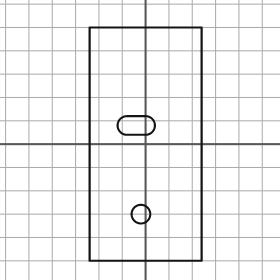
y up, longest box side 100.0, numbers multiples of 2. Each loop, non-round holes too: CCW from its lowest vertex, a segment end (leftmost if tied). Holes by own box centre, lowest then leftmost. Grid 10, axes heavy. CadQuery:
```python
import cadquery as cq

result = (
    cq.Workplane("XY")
    .moveTo(-24.0, -50.0)
    .lineTo(24.0, -50.0)
    .lineTo(24.0, 50.0)
    .lineTo(-24.0, 50.0)
    .close()
    .moveTo(-2.0, -30.0)
    .circle(4.0)
    .moveTo(-8.0, 4.0)
    .lineTo(0.0, 4.0)
    .threePointArc((4.0, 8.0), (0.0, 12.0))
    .lineTo(-8.0, 12.0)
    .threePointArc((-12.0, 8.0), (-8.0, 4.0))
    .close()
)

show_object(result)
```